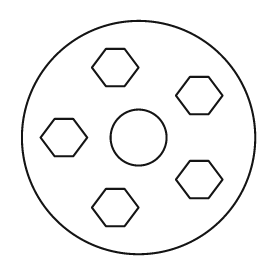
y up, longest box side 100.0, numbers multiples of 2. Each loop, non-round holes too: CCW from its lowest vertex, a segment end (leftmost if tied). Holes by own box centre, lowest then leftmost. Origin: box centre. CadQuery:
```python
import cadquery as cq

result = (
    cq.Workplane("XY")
    .moveTo(0.0, 0.0)
    .circle(50.0)
    .moveTo(-14.0, -38.0)
    .lineTo(-6.0, -38.0)
    .lineTo(0.0, -30.0)
    .lineTo(-6.0, -22.0)
    .lineTo(-14.0, -22.0)
    .lineTo(-20.0, -30.0)
    .close()
    .moveTo(22.0, -26.0)
    .lineTo(30.0, -26.0)
    .lineTo(36.0, -18.0)
    .lineTo(30.0, -10.0)
    .lineTo(22.0, -10.0)
    .lineTo(16.0, -18.0)
    .close()
    .moveTo(-36.0, -8.0)
    .lineTo(-28.0, -8.0)
    .lineTo(-22.0, 0.0)
    .lineTo(-28.0, 8.0)
    .lineTo(-36.0, 8.0)
    .lineTo(-42.0, 0.0)
    .close()
    .moveTo(0.0, 0.0)
    .circle(12.0)
    .moveTo(22.0, 10.0)
    .lineTo(30.0, 10.0)
    .lineTo(36.0, 18.0)
    .lineTo(30.0, 26.0)
    .lineTo(22.0, 26.0)
    .lineTo(16.0, 18.0)
    .close()
    .moveTo(-14.0, 22.0)
    .lineTo(-6.0, 22.0)
    .lineTo(0.0, 30.0)
    .lineTo(-6.0, 38.0)
    .lineTo(-14.0, 38.0)
    .lineTo(-20.0, 30.0)
    .close()
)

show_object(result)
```